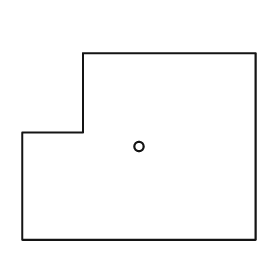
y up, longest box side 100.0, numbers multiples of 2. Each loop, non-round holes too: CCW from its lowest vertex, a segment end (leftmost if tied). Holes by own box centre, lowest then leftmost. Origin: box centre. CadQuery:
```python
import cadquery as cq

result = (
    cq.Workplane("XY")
    .moveTo(-50.0, -40.0)
    .lineTo(50.0, -40.0)
    .lineTo(50.0, 40.0)
    .lineTo(-24.0, 40.0)
    .lineTo(-24.0, 6.0)
    .lineTo(-50.0, 6.0)
    .close()
    .moveTo(0.0, 0.0)
    .circle(2.0)
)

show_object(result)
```